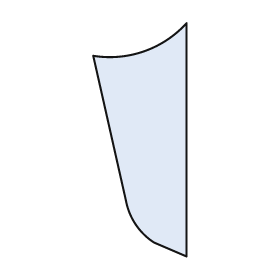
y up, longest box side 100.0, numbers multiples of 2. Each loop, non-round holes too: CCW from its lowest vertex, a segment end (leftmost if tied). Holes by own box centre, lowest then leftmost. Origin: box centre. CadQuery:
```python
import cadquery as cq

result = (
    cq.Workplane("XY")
    .moveTo(20.0, -50.0)
    .lineTo(20.0, 50.0)
    .threePointArc((2.0, 38.0), (-20.0, 36.0))
    .lineTo(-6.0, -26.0)
    .threePointArc((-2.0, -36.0), (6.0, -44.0))
    .close()
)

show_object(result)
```